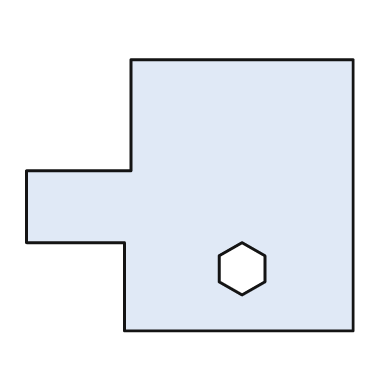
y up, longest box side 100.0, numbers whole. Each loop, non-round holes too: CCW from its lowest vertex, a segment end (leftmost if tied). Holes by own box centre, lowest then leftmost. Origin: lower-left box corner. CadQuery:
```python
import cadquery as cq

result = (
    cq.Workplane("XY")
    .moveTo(30.0, 0.0)
    .lineTo(100.0, 0.0)
    .lineTo(100.0, 83.0)
    .lineTo(32.0, 83.0)
    .lineTo(32.0, 49.0)
    .lineTo(0.0, 49.0)
    .lineTo(0.0, 27.0)
    .lineTo(30.0, 27.0)
    .close()
    .moveTo(66.0, 11.0)
    .lineTo(73.0, 15.0)
    .lineTo(73.0, 23.0)
    .lineTo(66.0, 27.0)
    .lineTo(59.0, 23.0)
    .lineTo(59.0, 15.0)
    .close()
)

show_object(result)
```